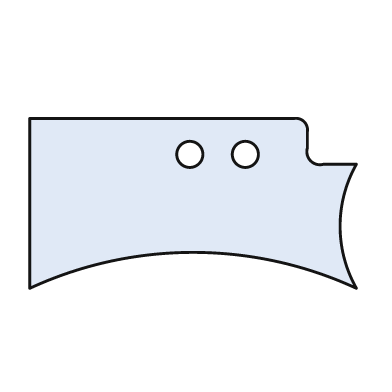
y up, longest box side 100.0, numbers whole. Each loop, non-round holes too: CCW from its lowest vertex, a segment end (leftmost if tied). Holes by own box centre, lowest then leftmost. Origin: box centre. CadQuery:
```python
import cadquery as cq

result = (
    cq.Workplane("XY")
    .moveTo(-50.0, -26.0)
    .threePointArc((0.0, -15.0), (50.0, -26.0))
    .threePointArc((45.0, -7.0), (50.0, 12.0))
    .lineTo(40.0, 12.0)
    .threePointArc((36.0, 13.0), (35.0, 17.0))
    .lineTo(35.0, 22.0)
    .threePointArc((34.0, 25.0), (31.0, 26.0))
    .lineTo(-50.0, 26.0)
    .close()
    .moveTo(-1.0, 15.0)
    .circle(4.0)
    .moveTo(16.0, 15.0)
    .circle(4.0)
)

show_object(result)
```